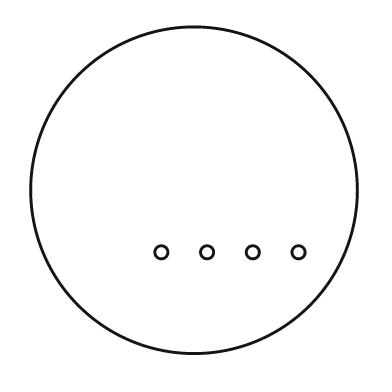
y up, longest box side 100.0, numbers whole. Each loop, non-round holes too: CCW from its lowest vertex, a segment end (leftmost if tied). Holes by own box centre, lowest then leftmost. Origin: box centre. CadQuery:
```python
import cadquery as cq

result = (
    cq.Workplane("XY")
    .moveTo(0.0, 0.0)
    .circle(50.0)
    .moveTo(-10.0, -19.0)
    .circle(2.0)
    .moveTo(4.0, -19.0)
    .circle(2.0)
    .moveTo(18.0, -19.0)
    .circle(2.0)
    .moveTo(32.0, -19.0)
    .circle(2.0)
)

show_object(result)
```